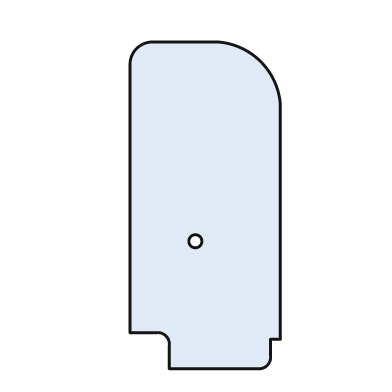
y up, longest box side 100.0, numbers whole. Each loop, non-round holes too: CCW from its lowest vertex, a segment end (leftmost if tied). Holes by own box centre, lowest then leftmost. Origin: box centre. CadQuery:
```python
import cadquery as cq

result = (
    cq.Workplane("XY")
    .moveTo(-11.0, -50.0)
    .lineTo(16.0, -50.0)
    .threePointArc((19.0, -49.0), (20.0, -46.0))
    .lineTo(20.0, -41.0)
    .lineTo(23.0, -41.0)
    .lineTo(23.0, 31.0)
    .threePointArc((17.0, 44.0), (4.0, 50.0))
    .lineTo(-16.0, 50.0)
    .threePointArc((-21.0, 48.0), (-23.0, 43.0))
    .lineTo(-23.0, -39.0)
    .lineTo(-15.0, -39.0)
    .threePointArc((-12.0, -40.0), (-11.0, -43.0))
    .close()
    .moveTo(-3.0, -11.0)
    .circle(2.0)
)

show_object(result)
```